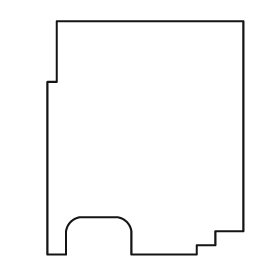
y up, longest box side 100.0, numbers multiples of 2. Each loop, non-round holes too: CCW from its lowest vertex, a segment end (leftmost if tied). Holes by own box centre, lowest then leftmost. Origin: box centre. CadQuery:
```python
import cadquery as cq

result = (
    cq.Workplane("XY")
    .moveTo(-42.0, -50.0)
    .lineTo(-34.0, -50.0)
    .lineTo(-34.0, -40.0)
    .threePointArc((-32.0, -36.0), (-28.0, -34.0))
    .lineTo(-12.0, -34.0)
    .threePointArc((-8.0, -36.0), (-6.0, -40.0))
    .lineTo(-6.0, -50.0)
    .lineTo(22.0, -50.0)
    .lineTo(22.0, -46.0)
    .lineTo(30.0, -46.0)
    .lineTo(30.0, -40.0)
    .lineTo(42.0, -40.0)
    .lineTo(42.0, 50.0)
    .lineTo(-38.0, 50.0)
    .lineTo(-38.0, 24.0)
    .lineTo(-42.0, 24.0)
    .close()
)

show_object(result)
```